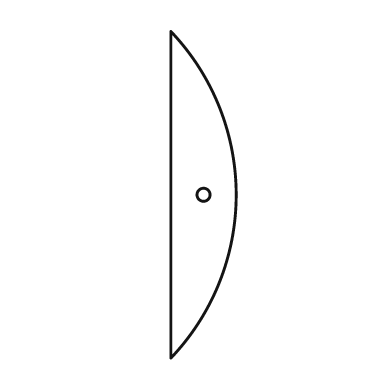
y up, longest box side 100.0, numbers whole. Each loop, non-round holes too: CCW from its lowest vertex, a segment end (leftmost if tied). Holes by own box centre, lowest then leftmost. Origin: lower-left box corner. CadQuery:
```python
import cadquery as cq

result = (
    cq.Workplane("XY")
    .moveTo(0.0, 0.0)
    .threePointArc((20.0, 50.0), (0.0, 100.0))
    .close()
    .moveTo(10.0, 50.0)
    .circle(2.0)
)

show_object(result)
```